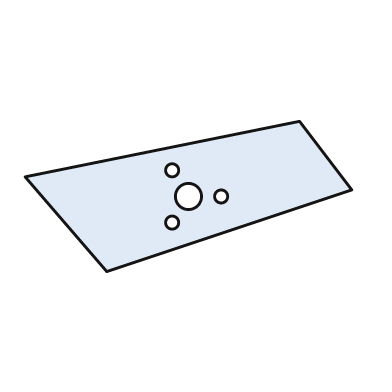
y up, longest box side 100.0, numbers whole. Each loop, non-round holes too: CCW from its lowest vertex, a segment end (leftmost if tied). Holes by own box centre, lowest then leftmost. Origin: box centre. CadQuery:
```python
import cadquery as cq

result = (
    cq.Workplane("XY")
    .moveTo(-25.0, -23.0)
    .lineTo(50.0, 2.0)
    .lineTo(34.0, 23.0)
    .lineTo(-50.0, 6.0)
    .close()
    .moveTo(-5.0, -8.0)
    .circle(2.0)
    .moveTo(0.0, 0.0)
    .circle(4.0)
    .moveTo(10.0, 0.0)
    .circle(2.0)
    .moveTo(-5.0, 8.0)
    .circle(2.0)
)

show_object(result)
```